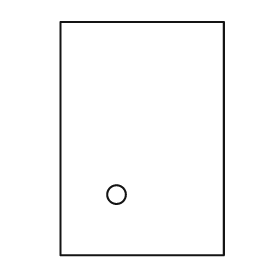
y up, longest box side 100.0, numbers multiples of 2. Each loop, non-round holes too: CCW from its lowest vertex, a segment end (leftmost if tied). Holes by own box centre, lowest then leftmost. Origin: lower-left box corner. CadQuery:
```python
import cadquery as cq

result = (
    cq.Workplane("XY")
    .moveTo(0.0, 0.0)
    .lineTo(70.0, 0.0)
    .lineTo(70.0, 100.0)
    .lineTo(0.0, 100.0)
    .close()
    .moveTo(24.0, 26.0)
    .circle(4.0)
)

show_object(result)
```